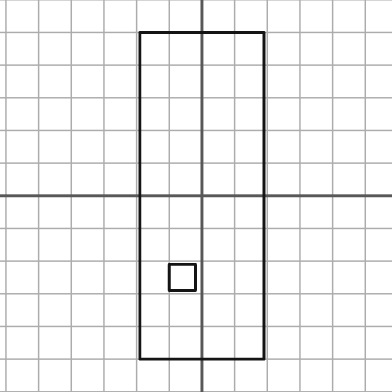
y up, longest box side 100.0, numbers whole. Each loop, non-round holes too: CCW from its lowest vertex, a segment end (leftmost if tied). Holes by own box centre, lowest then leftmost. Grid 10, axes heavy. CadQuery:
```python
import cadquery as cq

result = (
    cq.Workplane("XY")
    .moveTo(-19.0, -50.0)
    .lineTo(19.0, -50.0)
    .lineTo(19.0, 50.0)
    .lineTo(-19.0, 50.0)
    .close()
    .moveTo(-10.0, -29.0)
    .lineTo(-2.0, -29.0)
    .lineTo(-2.0, -21.0)
    .lineTo(-10.0, -21.0)
    .close()
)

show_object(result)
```